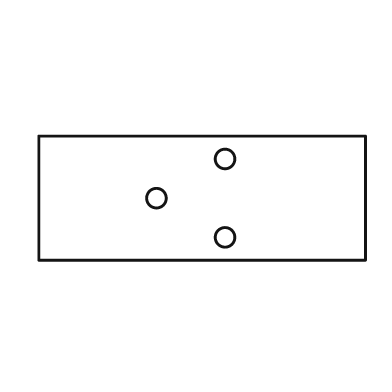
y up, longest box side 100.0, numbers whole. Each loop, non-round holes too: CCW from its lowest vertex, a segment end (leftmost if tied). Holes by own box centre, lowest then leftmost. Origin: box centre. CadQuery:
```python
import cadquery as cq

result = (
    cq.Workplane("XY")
    .moveTo(-50.0, -19.0)
    .lineTo(50.0, -19.0)
    .lineTo(50.0, 19.0)
    .lineTo(-50.0, 19.0)
    .close()
    .moveTo(7.0, -12.0)
    .circle(3.0)
    .moveTo(-14.0, 0.0)
    .circle(3.0)
    .moveTo(7.0, 12.0)
    .circle(3.0)
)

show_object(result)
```